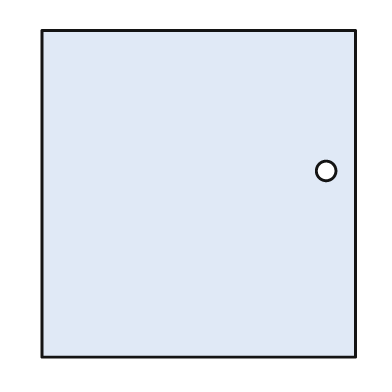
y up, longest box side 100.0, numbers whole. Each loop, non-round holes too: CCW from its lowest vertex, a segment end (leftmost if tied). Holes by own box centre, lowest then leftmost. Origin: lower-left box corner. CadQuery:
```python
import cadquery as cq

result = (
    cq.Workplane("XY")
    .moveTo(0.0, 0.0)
    .lineTo(96.0, 0.0)
    .lineTo(96.0, 100.0)
    .lineTo(0.0, 100.0)
    .close()
    .moveTo(87.0, 57.0)
    .circle(3.0)
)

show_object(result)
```